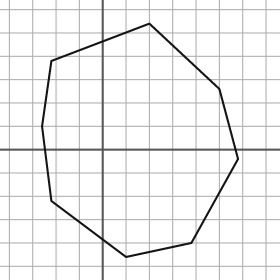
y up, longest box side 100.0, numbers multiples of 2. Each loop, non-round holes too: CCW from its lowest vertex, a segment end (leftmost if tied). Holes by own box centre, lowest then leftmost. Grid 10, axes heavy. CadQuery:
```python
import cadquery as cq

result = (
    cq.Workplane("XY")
    .moveTo(10.0, -46.0)
    .lineTo(38.0, -40.0)
    .lineTo(58.0, -4.0)
    .lineTo(50.0, 26.0)
    .lineTo(20.0, 54.0)
    .lineTo(-22.0, 38.0)
    .lineTo(-26.0, 10.0)
    .lineTo(-22.0, -22.0)
    .close()
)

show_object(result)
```